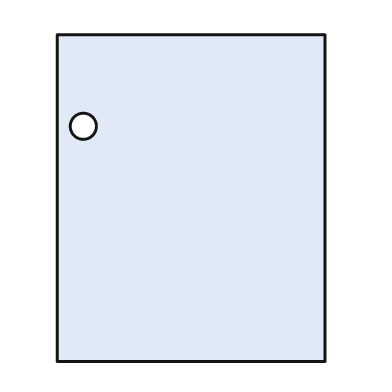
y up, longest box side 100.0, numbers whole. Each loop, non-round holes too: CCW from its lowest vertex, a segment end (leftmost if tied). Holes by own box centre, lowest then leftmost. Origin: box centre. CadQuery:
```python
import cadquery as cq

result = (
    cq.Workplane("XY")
    .moveTo(-41.0, -50.0)
    .lineTo(41.0, -50.0)
    .lineTo(41.0, 50.0)
    .lineTo(-41.0, 50.0)
    .close()
    .moveTo(-33.0, 22.0)
    .circle(4.0)
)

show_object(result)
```